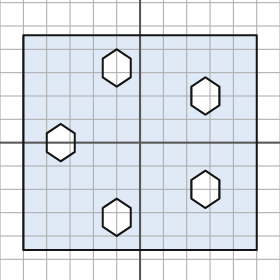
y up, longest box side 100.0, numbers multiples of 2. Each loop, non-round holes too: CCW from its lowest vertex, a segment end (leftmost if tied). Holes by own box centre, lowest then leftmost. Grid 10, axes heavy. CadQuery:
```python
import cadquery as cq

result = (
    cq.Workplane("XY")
    .moveTo(-50.0, -46.0)
    .lineTo(50.0, -46.0)
    .lineTo(50.0, 46.0)
    .lineTo(-50.0, 46.0)
    .close()
    .moveTo(-10.0, -40.0)
    .lineTo(-4.0, -36.0)
    .lineTo(-4.0, -28.0)
    .lineTo(-10.0, -24.0)
    .lineTo(-16.0, -28.0)
    .lineTo(-16.0, -36.0)
    .close()
    .moveTo(28.0, -28.0)
    .lineTo(34.0, -24.0)
    .lineTo(34.0, -16.0)
    .lineTo(28.0, -12.0)
    .lineTo(22.0, -16.0)
    .lineTo(22.0, -24.0)
    .close()
    .moveTo(-34.0, -8.0)
    .lineTo(-28.0, -4.0)
    .lineTo(-28.0, 4.0)
    .lineTo(-34.0, 8.0)
    .lineTo(-40.0, 4.0)
    .lineTo(-40.0, -4.0)
    .close()
    .moveTo(28.0, 12.0)
    .lineTo(34.0, 16.0)
    .lineTo(34.0, 24.0)
    .lineTo(28.0, 28.0)
    .lineTo(22.0, 24.0)
    .lineTo(22.0, 16.0)
    .close()
    .moveTo(-10.0, 24.0)
    .lineTo(-4.0, 28.0)
    .lineTo(-4.0, 36.0)
    .lineTo(-10.0, 40.0)
    .lineTo(-16.0, 36.0)
    .lineTo(-16.0, 28.0)
    .close()
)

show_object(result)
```